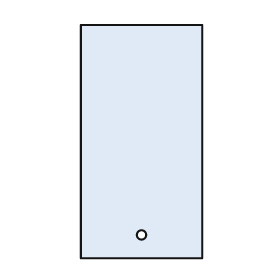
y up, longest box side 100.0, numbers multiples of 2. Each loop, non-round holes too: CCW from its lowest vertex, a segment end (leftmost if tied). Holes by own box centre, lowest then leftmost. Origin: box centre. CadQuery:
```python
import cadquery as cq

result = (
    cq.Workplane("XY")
    .moveTo(-26.0, -50.0)
    .lineTo(26.0, -50.0)
    .lineTo(26.0, 50.0)
    .lineTo(-26.0, 50.0)
    .close()
    .moveTo(0.0, -40.0)
    .circle(2.0)
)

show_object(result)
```